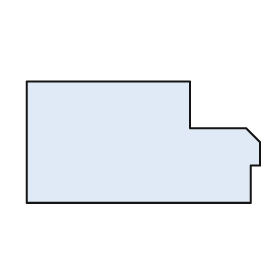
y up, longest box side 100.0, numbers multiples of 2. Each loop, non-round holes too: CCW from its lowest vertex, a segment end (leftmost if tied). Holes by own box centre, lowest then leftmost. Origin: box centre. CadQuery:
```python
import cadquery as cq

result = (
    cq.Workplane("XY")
    .moveTo(-50.0, -26.0)
    .lineTo(46.0, -26.0)
    .lineTo(46.0, -10.0)
    .lineTo(50.0, -10.0)
    .lineTo(50.0, 0.0)
    .lineTo(44.0, 6.0)
    .lineTo(20.0, 6.0)
    .lineTo(20.0, 26.0)
    .lineTo(-50.0, 26.0)
    .close()
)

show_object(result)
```